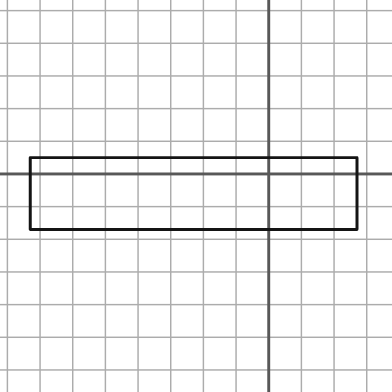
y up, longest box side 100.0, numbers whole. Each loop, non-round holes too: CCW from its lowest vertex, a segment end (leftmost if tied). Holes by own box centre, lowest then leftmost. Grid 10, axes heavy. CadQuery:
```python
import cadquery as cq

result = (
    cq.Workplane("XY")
    .moveTo(-73.0, -17.0)
    .lineTo(27.0, -17.0)
    .lineTo(27.0, 5.0)
    .lineTo(-73.0, 5.0)
    .close()
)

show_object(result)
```